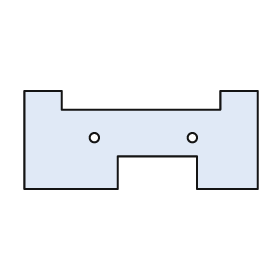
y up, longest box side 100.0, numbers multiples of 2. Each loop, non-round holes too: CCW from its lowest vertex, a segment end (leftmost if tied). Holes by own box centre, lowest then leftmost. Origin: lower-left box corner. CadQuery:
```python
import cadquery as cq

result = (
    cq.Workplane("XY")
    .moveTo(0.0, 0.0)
    .lineTo(40.0, 0.0)
    .lineTo(40.0, 14.0)
    .lineTo(74.0, 14.0)
    .lineTo(74.0, 0.0)
    .lineTo(100.0, 0.0)
    .lineTo(100.0, 42.0)
    .lineTo(84.0, 42.0)
    .lineTo(84.0, 34.0)
    .lineTo(16.0, 34.0)
    .lineTo(16.0, 42.0)
    .lineTo(0.0, 42.0)
    .close()
    .moveTo(30.0, 22.0)
    .circle(2.0)
    .moveTo(72.0, 22.0)
    .circle(2.0)
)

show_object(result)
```